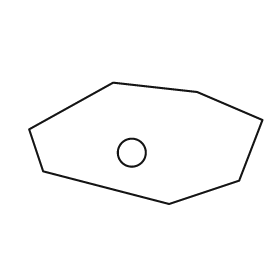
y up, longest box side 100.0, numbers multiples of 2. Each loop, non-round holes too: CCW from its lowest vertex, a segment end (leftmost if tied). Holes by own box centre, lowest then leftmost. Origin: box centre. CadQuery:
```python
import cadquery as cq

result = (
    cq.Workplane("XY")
    .moveTo(10.0, -26.0)
    .lineTo(40.0, -16.0)
    .lineTo(50.0, 10.0)
    .lineTo(22.0, 22.0)
    .lineTo(-14.0, 26.0)
    .lineTo(-50.0, 6.0)
    .lineTo(-44.0, -12.0)
    .close()
    .moveTo(-6.0, -4.0)
    .circle(6.0)
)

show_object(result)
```